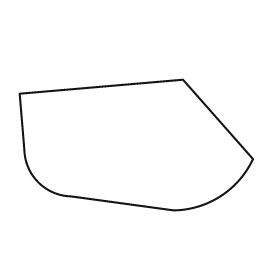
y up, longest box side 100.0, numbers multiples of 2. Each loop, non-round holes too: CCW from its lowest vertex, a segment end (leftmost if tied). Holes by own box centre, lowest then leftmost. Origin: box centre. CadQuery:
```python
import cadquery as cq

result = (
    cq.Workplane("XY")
    .moveTo(16.0, -28.0)
    .threePointArc((36.0, -22.0), (50.0, -6.0))
    .lineTo(20.0, 28.0)
    .lineTo(-50.0, 22.0)
    .lineTo(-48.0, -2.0)
    .threePointArc((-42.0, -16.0), (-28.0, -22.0))
    .close()
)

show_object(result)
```